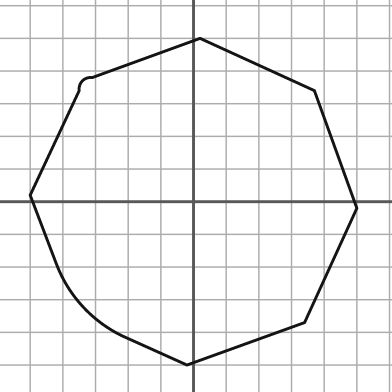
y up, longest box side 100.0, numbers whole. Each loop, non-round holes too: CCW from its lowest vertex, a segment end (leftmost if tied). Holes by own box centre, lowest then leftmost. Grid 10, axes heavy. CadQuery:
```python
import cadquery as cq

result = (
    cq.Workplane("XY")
    .moveTo(-2.0, -50.0)
    .lineTo(34.0, -37.0)
    .lineTo(50.0, -2.0)
    .lineTo(37.0, 34.0)
    .lineTo(2.0, 50.0)
    .lineTo(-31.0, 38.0)
    .threePointArc((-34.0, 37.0), (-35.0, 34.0))
    .lineTo(-50.0, 2.0)
    .lineTo(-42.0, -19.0)
    .threePointArc((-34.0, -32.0), (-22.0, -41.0))
    .close()
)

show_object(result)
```